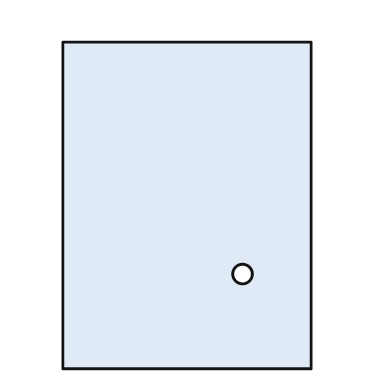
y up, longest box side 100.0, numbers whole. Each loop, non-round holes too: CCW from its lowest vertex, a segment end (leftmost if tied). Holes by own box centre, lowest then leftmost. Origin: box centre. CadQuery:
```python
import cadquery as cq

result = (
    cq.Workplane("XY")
    .moveTo(-38.0, -50.0)
    .lineTo(38.0, -50.0)
    .lineTo(38.0, 50.0)
    .lineTo(-38.0, 50.0)
    .close()
    .moveTo(17.0, -21.0)
    .circle(3.0)
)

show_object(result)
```